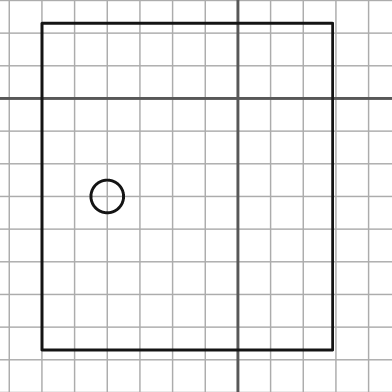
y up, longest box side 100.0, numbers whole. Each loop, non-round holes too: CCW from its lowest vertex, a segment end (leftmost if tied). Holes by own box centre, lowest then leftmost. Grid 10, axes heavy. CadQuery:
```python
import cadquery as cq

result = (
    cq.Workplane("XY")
    .moveTo(-60.0, -77.0)
    .lineTo(29.0, -77.0)
    .lineTo(29.0, 23.0)
    .lineTo(-60.0, 23.0)
    .close()
    .moveTo(-40.0, -30.0)
    .circle(5.0)
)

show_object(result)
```